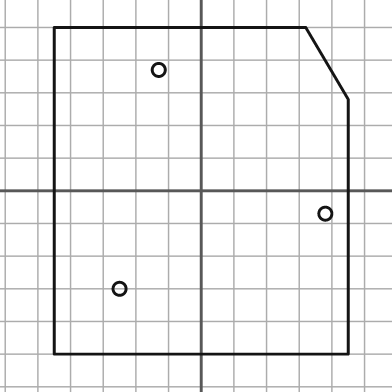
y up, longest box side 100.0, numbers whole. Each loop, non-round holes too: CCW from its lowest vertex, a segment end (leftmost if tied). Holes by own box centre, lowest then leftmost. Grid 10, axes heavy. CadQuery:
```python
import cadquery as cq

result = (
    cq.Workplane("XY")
    .moveTo(-45.0, -50.0)
    .lineTo(45.0, -50.0)
    .lineTo(45.0, 28.0)
    .lineTo(32.0, 50.0)
    .lineTo(-45.0, 50.0)
    .close()
    .moveTo(-25.0, -30.0)
    .circle(2.0)
    .moveTo(38.0, -7.0)
    .circle(2.0)
    .moveTo(-13.0, 37.0)
    .circle(2.0)
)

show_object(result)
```